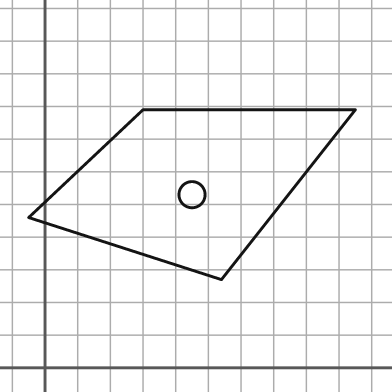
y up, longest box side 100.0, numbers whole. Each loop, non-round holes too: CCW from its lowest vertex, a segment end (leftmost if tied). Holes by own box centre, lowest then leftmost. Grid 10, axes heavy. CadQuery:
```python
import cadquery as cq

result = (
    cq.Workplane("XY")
    .moveTo(54.0, 27.0)
    .lineTo(95.0, 79.0)
    .lineTo(30.0, 79.0)
    .lineTo(-5.0, 46.0)
    .close()
    .moveTo(45.0, 53.0)
    .circle(4.0)
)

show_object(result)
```